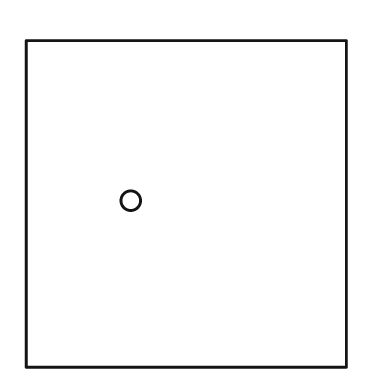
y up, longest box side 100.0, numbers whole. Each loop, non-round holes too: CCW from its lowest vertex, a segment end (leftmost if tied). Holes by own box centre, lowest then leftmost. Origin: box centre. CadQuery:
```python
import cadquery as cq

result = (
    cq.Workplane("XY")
    .moveTo(-49.0, -50.0)
    .lineTo(49.0, -50.0)
    .lineTo(49.0, 50.0)
    .lineTo(-49.0, 50.0)
    .close()
    .moveTo(-17.0, 1.0)
    .circle(3.0)
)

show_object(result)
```